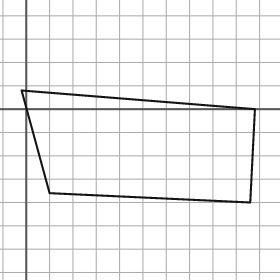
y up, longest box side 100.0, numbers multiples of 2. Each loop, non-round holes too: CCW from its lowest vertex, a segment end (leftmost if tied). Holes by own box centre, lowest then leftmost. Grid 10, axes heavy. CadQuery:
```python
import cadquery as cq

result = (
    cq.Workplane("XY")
    .moveTo(96.0, -40.0)
    .lineTo(98.0, 0.0)
    .lineTo(-2.0, 8.0)
    .lineTo(10.0, -36.0)
    .close()
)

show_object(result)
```